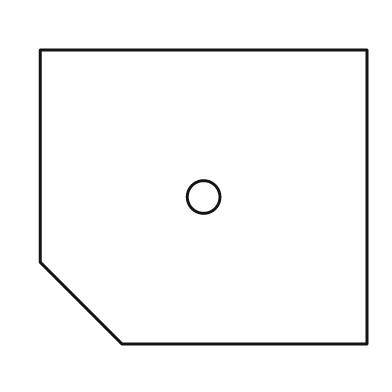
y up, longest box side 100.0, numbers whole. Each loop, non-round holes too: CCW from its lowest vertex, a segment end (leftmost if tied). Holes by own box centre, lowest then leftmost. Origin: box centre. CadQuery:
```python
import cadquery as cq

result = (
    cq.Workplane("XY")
    .moveTo(-25.0, -45.0)
    .lineTo(50.0, -45.0)
    .lineTo(50.0, 45.0)
    .lineTo(-50.0, 45.0)
    .lineTo(-50.0, -20.0)
    .close()
    .moveTo(0.0, 0.0)
    .circle(5.0)
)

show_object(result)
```